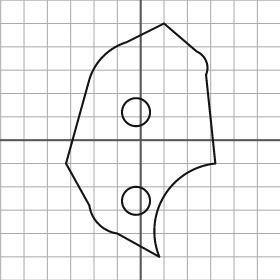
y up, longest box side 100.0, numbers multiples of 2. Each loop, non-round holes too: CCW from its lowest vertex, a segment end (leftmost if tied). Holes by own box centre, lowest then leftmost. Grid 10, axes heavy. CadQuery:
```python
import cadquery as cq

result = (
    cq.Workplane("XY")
    .moveTo(8.0, -50.0)
    .threePointArc((10.0, -24.0), (32.0, -10.0))
    .lineTo(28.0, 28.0)
    .threePointArc((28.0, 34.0), (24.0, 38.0))
    .lineTo(10.0, 50.0)
    .lineTo(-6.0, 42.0)
    .threePointArc((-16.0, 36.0), (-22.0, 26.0))
    .lineTo(-32.0, -10.0)
    .lineTo(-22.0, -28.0)
    .threePointArc((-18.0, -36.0), (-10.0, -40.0))
    .close()
    .moveTo(-2.0, -26.0)
    .circle(6.0)
    .moveTo(-2.0, 12.0)
    .circle(6.0)
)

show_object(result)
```